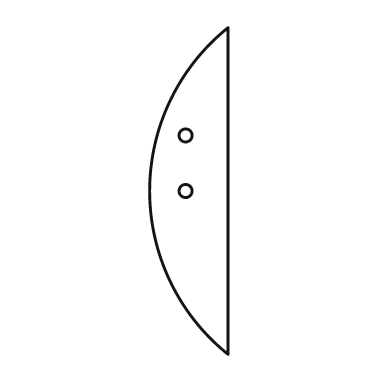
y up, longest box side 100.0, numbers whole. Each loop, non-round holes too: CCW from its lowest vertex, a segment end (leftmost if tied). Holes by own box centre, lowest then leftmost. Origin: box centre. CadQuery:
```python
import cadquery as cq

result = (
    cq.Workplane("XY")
    .moveTo(12.0, -50.0)
    .lineTo(12.0, 50.0)
    .threePointArc((-12.0, 0.0), (12.0, -50.0))
    .close()
    .moveTo(-1.0, 0.0)
    .circle(2.0)
    .moveTo(-1.0, 17.0)
    .circle(2.0)
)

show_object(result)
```